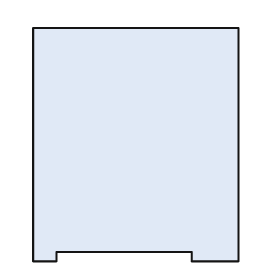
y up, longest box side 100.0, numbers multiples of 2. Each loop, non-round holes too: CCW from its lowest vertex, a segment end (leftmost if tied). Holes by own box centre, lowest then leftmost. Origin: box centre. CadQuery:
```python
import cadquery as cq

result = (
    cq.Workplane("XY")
    .moveTo(-44.0, -50.0)
    .lineTo(-34.0, -50.0)
    .lineTo(-34.0, -46.0)
    .lineTo(24.0, -46.0)
    .lineTo(24.0, -50.0)
    .lineTo(44.0, -50.0)
    .lineTo(44.0, 50.0)
    .lineTo(-44.0, 50.0)
    .close()
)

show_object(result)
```